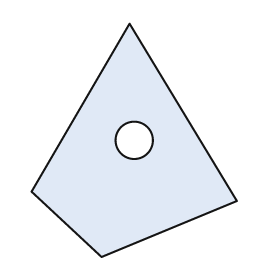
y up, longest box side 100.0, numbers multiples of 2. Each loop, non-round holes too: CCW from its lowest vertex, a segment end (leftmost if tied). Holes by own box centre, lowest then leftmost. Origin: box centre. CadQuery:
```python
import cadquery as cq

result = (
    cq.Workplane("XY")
    .moveTo(-14.0, -50.0)
    .lineTo(44.0, -26.0)
    .lineTo(-2.0, 50.0)
    .lineTo(-44.0, -22.0)
    .close()
    .moveTo(0.0, 0.0)
    .circle(8.0)
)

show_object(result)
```